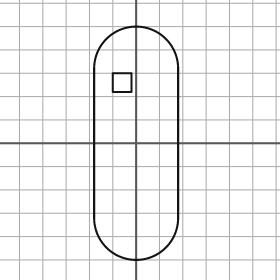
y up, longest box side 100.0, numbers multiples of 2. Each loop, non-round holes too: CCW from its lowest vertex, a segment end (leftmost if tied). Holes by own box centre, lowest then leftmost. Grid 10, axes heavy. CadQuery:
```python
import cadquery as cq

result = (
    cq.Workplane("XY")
    .moveTo(-18.0, -32.0)
    .threePointArc((0.0, -50.0), (18.0, -32.0))
    .lineTo(18.0, 32.0)
    .threePointArc((0.0, 50.0), (-18.0, 32.0))
    .close()
    .moveTo(-10.0, 22.0)
    .lineTo(-2.0, 22.0)
    .lineTo(-2.0, 30.0)
    .lineTo(-10.0, 30.0)
    .close()
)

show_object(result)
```